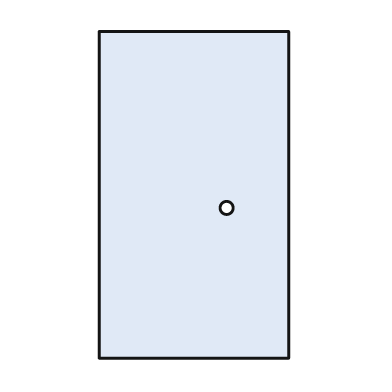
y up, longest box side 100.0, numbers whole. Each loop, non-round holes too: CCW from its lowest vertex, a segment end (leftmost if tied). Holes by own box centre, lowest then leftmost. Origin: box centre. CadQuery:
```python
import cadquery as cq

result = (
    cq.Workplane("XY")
    .moveTo(-29.0, -50.0)
    .lineTo(29.0, -50.0)
    .lineTo(29.0, 50.0)
    .lineTo(-29.0, 50.0)
    .close()
    .moveTo(10.0, -4.0)
    .circle(2.0)
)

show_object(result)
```